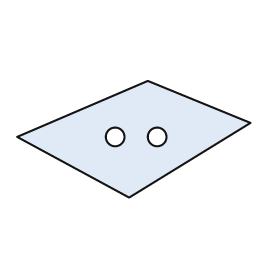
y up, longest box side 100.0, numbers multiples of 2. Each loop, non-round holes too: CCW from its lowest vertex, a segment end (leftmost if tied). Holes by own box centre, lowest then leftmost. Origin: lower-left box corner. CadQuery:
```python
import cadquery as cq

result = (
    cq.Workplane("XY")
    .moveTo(48.0, 0.0)
    .lineTo(100.0, 32.0)
    .lineTo(56.0, 50.0)
    .lineTo(0.0, 26.0)
    .close()
    .moveTo(42.0, 26.0)
    .circle(4.0)
    .moveTo(60.0, 26.0)
    .circle(4.0)
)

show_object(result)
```